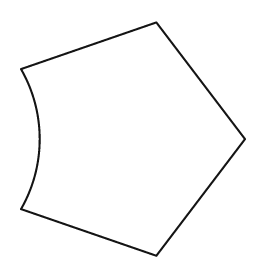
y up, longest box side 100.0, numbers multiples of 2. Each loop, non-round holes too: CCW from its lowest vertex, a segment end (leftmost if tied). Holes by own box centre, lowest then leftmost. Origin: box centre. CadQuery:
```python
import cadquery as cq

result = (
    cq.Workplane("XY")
    .moveTo(10.0, -50.0)
    .lineTo(48.0, 0.0)
    .lineTo(10.0, 50.0)
    .lineTo(-48.0, 30.0)
    .threePointArc((-40.0, 0.0), (-48.0, -30.0))
    .close()
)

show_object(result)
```